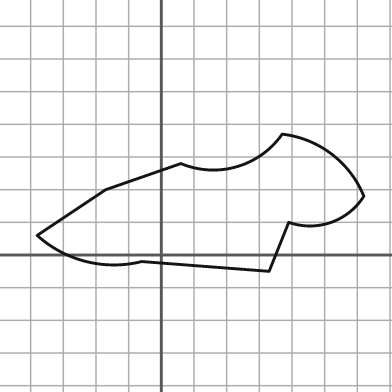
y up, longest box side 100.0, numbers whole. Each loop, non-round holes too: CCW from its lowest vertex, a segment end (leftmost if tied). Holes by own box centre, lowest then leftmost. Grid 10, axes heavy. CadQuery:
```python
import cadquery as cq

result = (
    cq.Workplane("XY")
    .moveTo(33.0, -5.0)
    .lineTo(39.0, 10.0)
    .threePointArc((52.0, 10.0), (62.0, 18.0))
    .threePointArc((52.0, 31.0), (37.0, 37.0))
    .threePointArc((23.0, 27.0), (6.0, 28.0))
    .lineTo(-17.0, 20.0)
    .lineTo(-38.0, 6.0)
    .threePointArc((-23.0, -2.0), (-6.0, -2.0))
    .close()
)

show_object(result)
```